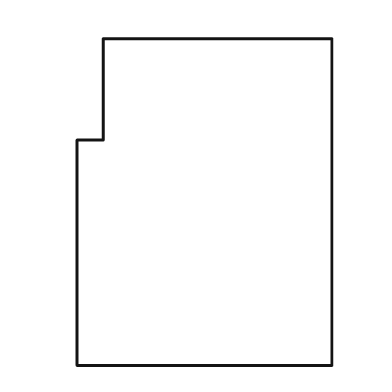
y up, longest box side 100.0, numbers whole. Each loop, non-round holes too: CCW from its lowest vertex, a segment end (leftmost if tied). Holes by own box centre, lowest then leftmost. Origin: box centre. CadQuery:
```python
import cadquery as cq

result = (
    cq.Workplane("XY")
    .moveTo(-39.0, -50.0)
    .lineTo(39.0, -50.0)
    .lineTo(39.0, 50.0)
    .lineTo(-31.0, 50.0)
    .lineTo(-31.0, 19.0)
    .lineTo(-39.0, 19.0)
    .close()
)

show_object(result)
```